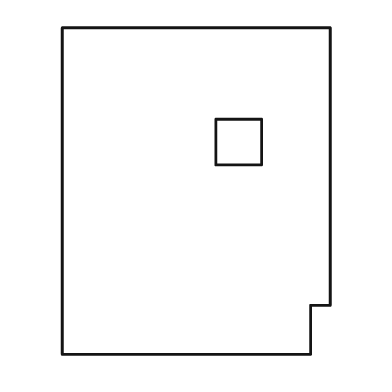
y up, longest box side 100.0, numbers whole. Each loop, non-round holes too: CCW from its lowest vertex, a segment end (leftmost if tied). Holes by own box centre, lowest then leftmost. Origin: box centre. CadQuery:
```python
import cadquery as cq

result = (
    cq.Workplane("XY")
    .moveTo(-41.0, -50.0)
    .lineTo(35.0, -50.0)
    .lineTo(35.0, -35.0)
    .lineTo(41.0, -35.0)
    .lineTo(41.0, 50.0)
    .lineTo(-41.0, 50.0)
    .close()
    .moveTo(6.0, 8.0)
    .lineTo(20.0, 8.0)
    .lineTo(20.0, 22.0)
    .lineTo(6.0, 22.0)
    .close()
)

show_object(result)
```